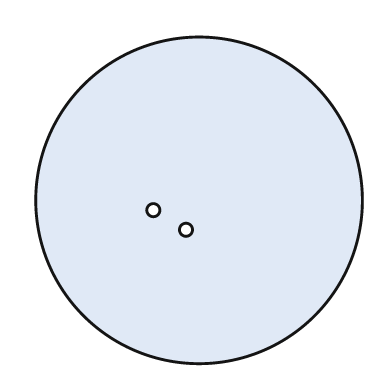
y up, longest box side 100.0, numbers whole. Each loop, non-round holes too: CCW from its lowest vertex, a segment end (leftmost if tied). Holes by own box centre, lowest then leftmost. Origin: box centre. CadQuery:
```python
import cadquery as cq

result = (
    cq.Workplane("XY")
    .moveTo(0.0, 0.0)
    .circle(50.0)
    .moveTo(-4.0, -9.0)
    .circle(2.0)
    .moveTo(-14.0, -3.0)
    .circle(2.0)
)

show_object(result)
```